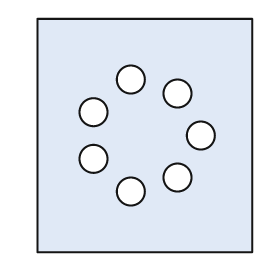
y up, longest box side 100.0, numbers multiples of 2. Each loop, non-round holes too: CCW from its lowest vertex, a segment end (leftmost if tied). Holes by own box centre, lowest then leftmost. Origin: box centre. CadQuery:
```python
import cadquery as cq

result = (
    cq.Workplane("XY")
    .moveTo(-46.0, -50.0)
    .lineTo(46.0, -50.0)
    .lineTo(46.0, 50.0)
    .lineTo(-46.0, 50.0)
    .close()
    .moveTo(-6.0, -24.0)
    .circle(6.0)
    .moveTo(14.0, -18.0)
    .circle(6.0)
    .moveTo(-22.0, -10.0)
    .circle(6.0)
    .moveTo(24.0, 0.0)
    .circle(6.0)
    .moveTo(-22.0, 10.0)
    .circle(6.0)
    .moveTo(14.0, 18.0)
    .circle(6.0)
    .moveTo(-6.0, 24.0)
    .circle(6.0)
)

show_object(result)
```